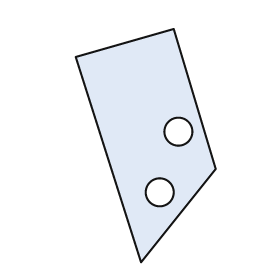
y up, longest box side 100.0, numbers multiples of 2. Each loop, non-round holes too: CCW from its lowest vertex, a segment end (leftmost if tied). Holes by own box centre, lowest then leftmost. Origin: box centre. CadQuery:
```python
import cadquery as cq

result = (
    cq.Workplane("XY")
    .moveTo(-2.0, -50.0)
    .lineTo(30.0, -10.0)
    .lineTo(12.0, 50.0)
    .lineTo(-30.0, 38.0)
    .close()
    .moveTo(6.0, -20.0)
    .circle(6.0)
    .moveTo(14.0, 6.0)
    .circle(6.0)
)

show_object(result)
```